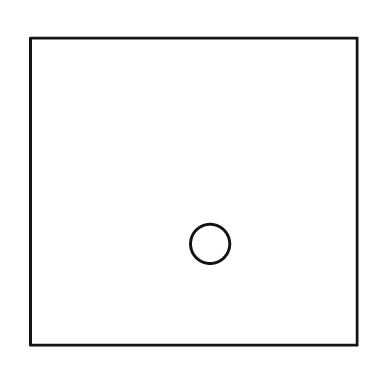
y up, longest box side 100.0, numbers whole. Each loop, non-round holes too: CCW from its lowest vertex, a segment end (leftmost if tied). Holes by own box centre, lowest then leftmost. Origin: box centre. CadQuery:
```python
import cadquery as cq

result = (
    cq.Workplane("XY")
    .moveTo(-50.0, -47.0)
    .lineTo(50.0, -47.0)
    .lineTo(50.0, 47.0)
    .lineTo(-50.0, 47.0)
    .close()
    .moveTo(5.0, -16.0)
    .circle(6.0)
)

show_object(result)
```